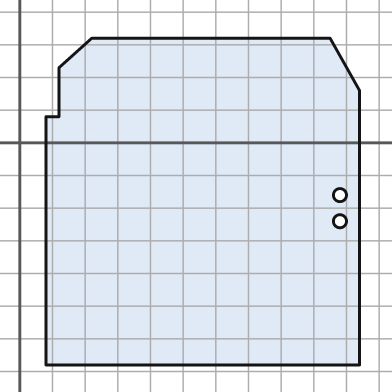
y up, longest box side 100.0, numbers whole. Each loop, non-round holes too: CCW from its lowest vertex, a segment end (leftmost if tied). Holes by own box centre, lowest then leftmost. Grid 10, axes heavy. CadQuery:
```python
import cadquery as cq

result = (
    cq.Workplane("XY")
    .moveTo(8.0, -68.0)
    .lineTo(104.0, -68.0)
    .lineTo(104.0, 16.0)
    .lineTo(95.0, 32.0)
    .lineTo(22.0, 32.0)
    .lineTo(12.0, 23.0)
    .lineTo(12.0, 8.0)
    .lineTo(8.0, 8.0)
    .close()
    .moveTo(98.0, -24.0)
    .circle(2.0)
    .moveTo(98.0, -16.0)
    .circle(2.0)
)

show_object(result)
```